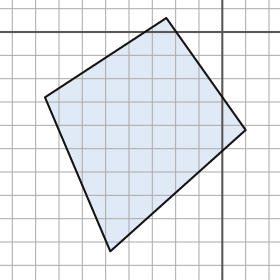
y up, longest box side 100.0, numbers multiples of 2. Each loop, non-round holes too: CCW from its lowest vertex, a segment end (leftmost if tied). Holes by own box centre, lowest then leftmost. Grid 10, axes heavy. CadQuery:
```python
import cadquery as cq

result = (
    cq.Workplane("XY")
    .moveTo(-48.0, -94.0)
    .lineTo(10.0, -42.0)
    .lineTo(-24.0, 6.0)
    .lineTo(-76.0, -28.0)
    .close()
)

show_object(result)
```